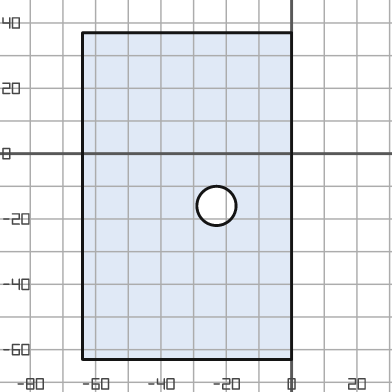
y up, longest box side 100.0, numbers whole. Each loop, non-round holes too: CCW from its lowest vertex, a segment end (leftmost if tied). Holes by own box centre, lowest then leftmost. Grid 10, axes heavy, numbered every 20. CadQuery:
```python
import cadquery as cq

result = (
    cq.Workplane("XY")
    .moveTo(-64.0, -63.0)
    .lineTo(0.0, -63.0)
    .lineTo(0.0, 37.0)
    .lineTo(-64.0, 37.0)
    .close()
    .moveTo(-23.0, -16.0)
    .circle(6.0)
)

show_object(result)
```